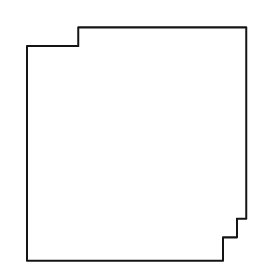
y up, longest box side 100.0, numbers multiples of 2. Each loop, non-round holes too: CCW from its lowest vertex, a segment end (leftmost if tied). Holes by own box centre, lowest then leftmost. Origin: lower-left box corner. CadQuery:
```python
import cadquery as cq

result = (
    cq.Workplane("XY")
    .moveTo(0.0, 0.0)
    .lineTo(84.0, 0.0)
    .lineTo(84.0, 10.0)
    .lineTo(90.0, 10.0)
    .lineTo(90.0, 18.0)
    .lineTo(94.0, 18.0)
    .lineTo(94.0, 100.0)
    .lineTo(22.0, 100.0)
    .lineTo(22.0, 92.0)
    .lineTo(0.0, 92.0)
    .close()
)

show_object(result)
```